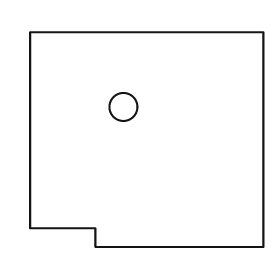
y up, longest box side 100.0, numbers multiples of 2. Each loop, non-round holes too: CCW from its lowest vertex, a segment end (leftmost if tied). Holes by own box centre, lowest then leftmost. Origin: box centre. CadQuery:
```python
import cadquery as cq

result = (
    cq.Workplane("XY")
    .moveTo(-22.0, -46.0)
    .lineTo(50.0, -46.0)
    .lineTo(50.0, 46.0)
    .lineTo(-50.0, 46.0)
    .lineTo(-50.0, -38.0)
    .lineTo(-22.0, -38.0)
    .close()
    .moveTo(-10.0, 14.0)
    .circle(6.0)
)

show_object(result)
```